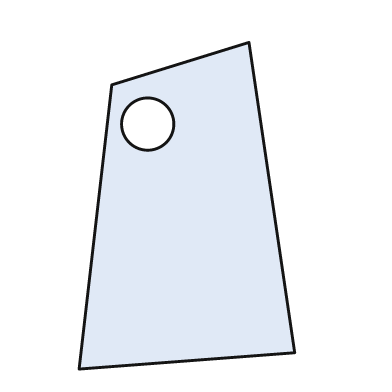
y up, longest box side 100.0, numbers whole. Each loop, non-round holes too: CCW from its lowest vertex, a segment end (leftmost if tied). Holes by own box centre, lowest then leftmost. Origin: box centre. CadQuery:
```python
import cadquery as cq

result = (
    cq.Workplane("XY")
    .moveTo(-33.0, -50.0)
    .lineTo(33.0, -45.0)
    .lineTo(19.0, 50.0)
    .lineTo(-23.0, 37.0)
    .close()
    .moveTo(-12.0, 25.0)
    .circle(8.0)
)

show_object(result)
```